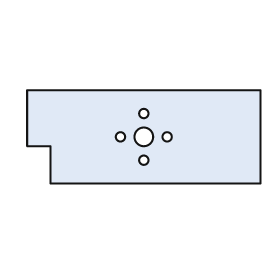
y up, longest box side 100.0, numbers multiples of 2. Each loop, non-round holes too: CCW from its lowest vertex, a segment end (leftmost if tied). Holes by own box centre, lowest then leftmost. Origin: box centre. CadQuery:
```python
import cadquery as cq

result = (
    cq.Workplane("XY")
    .moveTo(-40.0, -20.0)
    .lineTo(50.0, -20.0)
    .lineTo(50.0, 20.0)
    .lineTo(-50.0, 20.0)
    .lineTo(-50.0, -4.0)
    .lineTo(-40.0, -4.0)
    .close()
    .moveTo(0.0, -10.0)
    .circle(2.0)
    .moveTo(-10.0, 0.0)
    .circle(2.0)
    .moveTo(0.0, 0.0)
    .circle(4.0)
    .moveTo(10.0, 0.0)
    .circle(2.0)
    .moveTo(0.0, 10.0)
    .circle(2.0)
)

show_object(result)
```